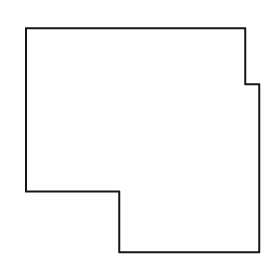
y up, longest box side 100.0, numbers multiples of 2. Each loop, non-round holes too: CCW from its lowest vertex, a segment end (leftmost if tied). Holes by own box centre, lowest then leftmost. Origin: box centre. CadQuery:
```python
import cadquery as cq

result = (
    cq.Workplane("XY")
    .moveTo(-10.0, -48.0)
    .lineTo(50.0, -48.0)
    .lineTo(50.0, 24.0)
    .lineTo(44.0, 24.0)
    .lineTo(44.0, 48.0)
    .lineTo(-50.0, 48.0)
    .lineTo(-50.0, -22.0)
    .lineTo(-10.0, -22.0)
    .close()
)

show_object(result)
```